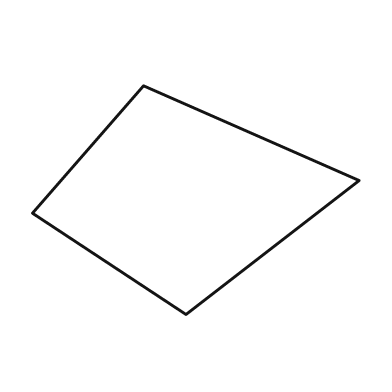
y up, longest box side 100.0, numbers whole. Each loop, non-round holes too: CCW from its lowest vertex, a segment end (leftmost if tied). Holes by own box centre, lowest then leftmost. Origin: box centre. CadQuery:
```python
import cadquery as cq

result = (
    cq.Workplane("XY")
    .moveTo(-3.0, -35.0)
    .lineTo(50.0, 6.0)
    .lineTo(-16.0, 35.0)
    .lineTo(-50.0, -4.0)
    .close()
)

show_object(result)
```